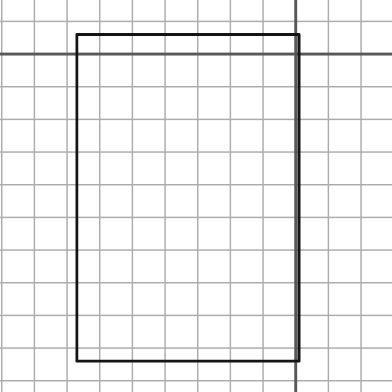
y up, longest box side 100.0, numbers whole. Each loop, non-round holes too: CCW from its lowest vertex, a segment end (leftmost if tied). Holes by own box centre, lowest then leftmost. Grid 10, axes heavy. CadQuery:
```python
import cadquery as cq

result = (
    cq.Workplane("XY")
    .moveTo(-67.0, -94.0)
    .lineTo(1.0, -94.0)
    .lineTo(1.0, 6.0)
    .lineTo(-67.0, 6.0)
    .close()
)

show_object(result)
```